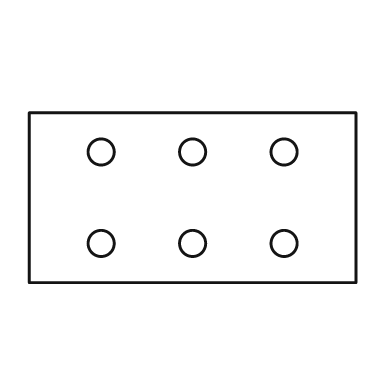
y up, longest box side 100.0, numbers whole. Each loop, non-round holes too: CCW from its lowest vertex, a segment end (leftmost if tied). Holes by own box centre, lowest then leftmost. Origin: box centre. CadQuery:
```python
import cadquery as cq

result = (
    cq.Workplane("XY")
    .moveTo(-50.0, -26.0)
    .lineTo(50.0, -26.0)
    .lineTo(50.0, 26.0)
    .lineTo(-50.0, 26.0)
    .close()
    .moveTo(-28.0, -14.0)
    .circle(4.0)
    .moveTo(0.0, -14.0)
    .circle(4.0)
    .moveTo(28.0, -14.0)
    .circle(4.0)
    .moveTo(-28.0, 14.0)
    .circle(4.0)
    .moveTo(0.0, 14.0)
    .circle(4.0)
    .moveTo(28.0, 14.0)
    .circle(4.0)
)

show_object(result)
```